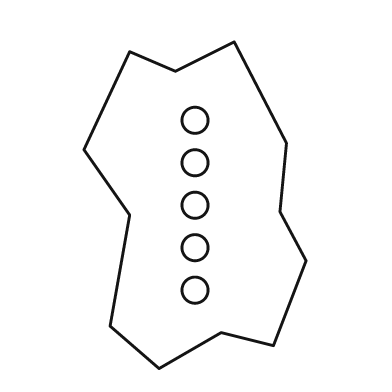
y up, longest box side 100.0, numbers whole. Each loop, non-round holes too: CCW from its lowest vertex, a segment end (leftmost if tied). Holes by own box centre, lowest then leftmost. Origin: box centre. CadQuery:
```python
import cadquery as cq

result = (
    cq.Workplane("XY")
    .moveTo(-11.0, -50.0)
    .lineTo(8.0, -39.0)
    .lineTo(24.0, -43.0)
    .lineTo(34.0, -17.0)
    .lineTo(26.0, -2.0)
    .lineTo(28.0, 19.0)
    .lineTo(12.0, 50.0)
    .lineTo(-6.0, 41.0)
    .lineTo(-20.0, 47.0)
    .lineTo(-34.0, 17.0)
    .lineTo(-20.0, -3.0)
    .lineTo(-26.0, -37.0)
    .close()
    .moveTo(0.0, -26.0)
    .circle(4.0)
    .moveTo(0.0, -13.0)
    .circle(4.0)
    .moveTo(0.0, 0.0)
    .circle(4.0)
    .moveTo(0.0, 13.0)
    .circle(4.0)
    .moveTo(0.0, 26.0)
    .circle(4.0)
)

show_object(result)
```